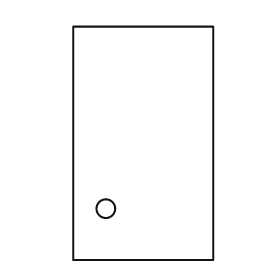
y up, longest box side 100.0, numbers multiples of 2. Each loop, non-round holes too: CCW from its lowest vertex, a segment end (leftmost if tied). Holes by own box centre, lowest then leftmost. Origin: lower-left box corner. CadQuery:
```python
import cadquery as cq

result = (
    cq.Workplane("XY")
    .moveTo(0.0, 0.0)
    .lineTo(60.0, 0.0)
    .lineTo(60.0, 100.0)
    .lineTo(0.0, 100.0)
    .close()
    .moveTo(14.0, 22.0)
    .circle(4.0)
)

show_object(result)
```